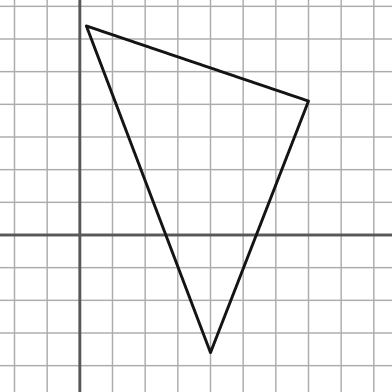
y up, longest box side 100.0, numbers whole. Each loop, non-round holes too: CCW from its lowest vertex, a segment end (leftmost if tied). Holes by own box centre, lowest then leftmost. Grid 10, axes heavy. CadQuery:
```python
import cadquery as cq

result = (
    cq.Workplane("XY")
    .moveTo(40.0, -36.0)
    .lineTo(70.0, 41.0)
    .lineTo(2.0, 64.0)
    .close()
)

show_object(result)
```